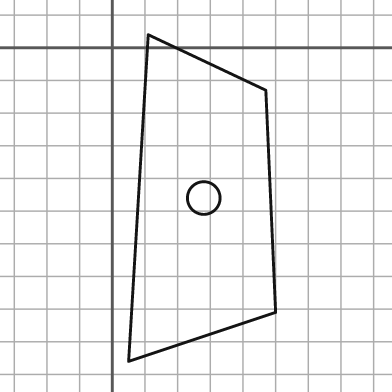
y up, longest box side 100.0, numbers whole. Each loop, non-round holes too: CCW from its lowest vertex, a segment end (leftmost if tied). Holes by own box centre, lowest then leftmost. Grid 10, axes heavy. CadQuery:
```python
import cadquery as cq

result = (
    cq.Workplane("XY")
    .moveTo(5.0, -96.0)
    .lineTo(50.0, -81.0)
    .lineTo(47.0, -13.0)
    .lineTo(11.0, 4.0)
    .close()
    .moveTo(28.0, -46.0)
    .circle(5.0)
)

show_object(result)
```